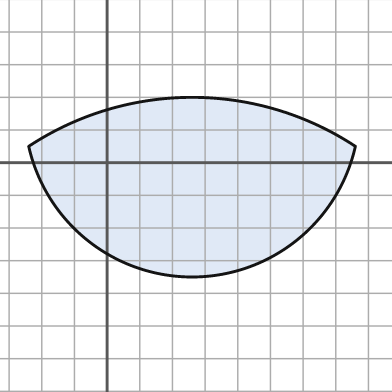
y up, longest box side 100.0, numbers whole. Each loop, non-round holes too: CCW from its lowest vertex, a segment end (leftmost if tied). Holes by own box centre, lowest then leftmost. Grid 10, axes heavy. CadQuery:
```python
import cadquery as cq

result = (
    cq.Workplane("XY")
    .moveTo(-24.0, 5.0)
    .threePointArc((26.0, -35.0), (76.0, 5.0))
    .threePointArc((26.0, 20.0), (-24.0, 5.0))
    .close()
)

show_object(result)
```